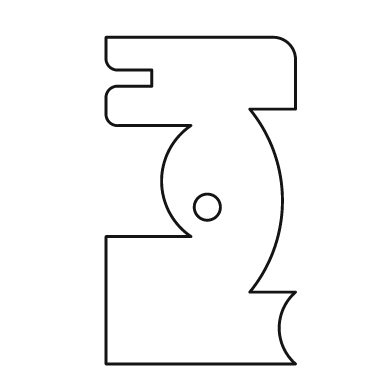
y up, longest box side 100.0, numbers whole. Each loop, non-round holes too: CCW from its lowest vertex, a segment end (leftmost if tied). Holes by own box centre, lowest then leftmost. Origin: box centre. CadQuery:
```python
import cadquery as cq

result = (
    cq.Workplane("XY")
    .moveTo(-29.0, -50.0)
    .lineTo(29.0, -50.0)
    .threePointArc((24.0, -39.0), (29.0, -28.0))
    .lineTo(15.0, -28.0)
    .threePointArc((25.0, 0.0), (15.0, 28.0))
    .lineTo(29.0, 28.0)
    .lineTo(29.0, 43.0)
    .threePointArc((27.0, 48.0), (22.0, 50.0))
    .lineTo(-29.0, 50.0)
    .lineTo(-29.0, 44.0)
    .threePointArc((-28.0, 41.0), (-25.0, 40.0))
    .lineTo(-15.0, 40.0)
    .lineTo(-15.0, 35.0)
    .lineTo(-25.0, 35.0)
    .threePointArc((-28.0, 34.0), (-29.0, 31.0))
    .lineTo(-29.0, 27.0)
    .threePointArc((-28.0, 24.0), (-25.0, 23.0))
    .lineTo(-3.0, 23.0)
    .threePointArc((-12.0, 6.0), (-3.0, -11.0))
    .lineTo(-29.0, -11.0)
    .close()
    .moveTo(2.0, -2.0)
    .circle(4.0)
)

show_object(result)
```